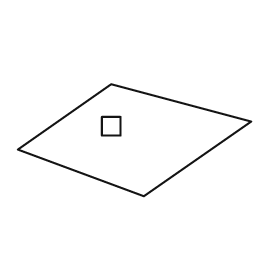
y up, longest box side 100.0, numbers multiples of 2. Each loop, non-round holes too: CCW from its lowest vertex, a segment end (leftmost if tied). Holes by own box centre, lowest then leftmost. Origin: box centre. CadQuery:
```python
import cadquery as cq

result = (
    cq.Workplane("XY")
    .moveTo(4.0, -24.0)
    .lineTo(50.0, 8.0)
    .lineTo(-10.0, 24.0)
    .lineTo(-50.0, -4.0)
    .close()
    .moveTo(-14.0, 2.0)
    .lineTo(-6.0, 2.0)
    .lineTo(-6.0, 10.0)
    .lineTo(-14.0, 10.0)
    .close()
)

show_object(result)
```